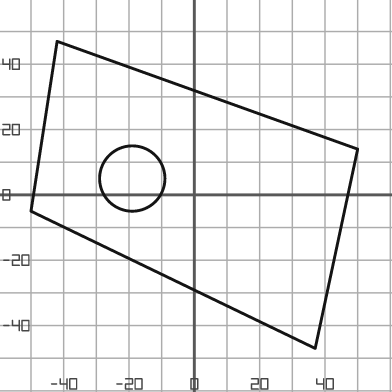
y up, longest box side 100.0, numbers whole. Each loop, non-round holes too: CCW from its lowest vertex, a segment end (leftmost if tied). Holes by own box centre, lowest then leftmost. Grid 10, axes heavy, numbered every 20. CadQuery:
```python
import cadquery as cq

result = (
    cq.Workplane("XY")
    .moveTo(37.0, -47.0)
    .lineTo(50.0, 14.0)
    .lineTo(-42.0, 47.0)
    .lineTo(-50.0, -5.0)
    .close()
    .moveTo(-19.0, 5.0)
    .circle(10.0)
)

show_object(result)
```